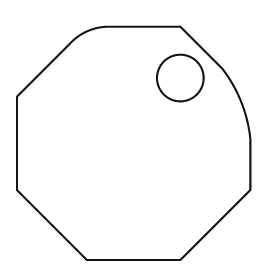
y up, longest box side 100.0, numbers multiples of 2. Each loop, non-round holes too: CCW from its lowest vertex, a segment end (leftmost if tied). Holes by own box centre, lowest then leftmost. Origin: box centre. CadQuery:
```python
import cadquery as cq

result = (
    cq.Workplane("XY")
    .moveTo(-20.0, -50.0)
    .lineTo(20.0, -50.0)
    .lineTo(50.0, -20.0)
    .lineTo(50.0, 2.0)
    .threePointArc((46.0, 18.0), (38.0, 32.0))
    .lineTo(20.0, 50.0)
    .lineTo(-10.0, 50.0)
    .threePointArc((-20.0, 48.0), (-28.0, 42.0))
    .lineTo(-50.0, 20.0)
    .lineTo(-50.0, -20.0)
    .close()
    .moveTo(20.0, 28.0)
    .circle(10.0)
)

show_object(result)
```